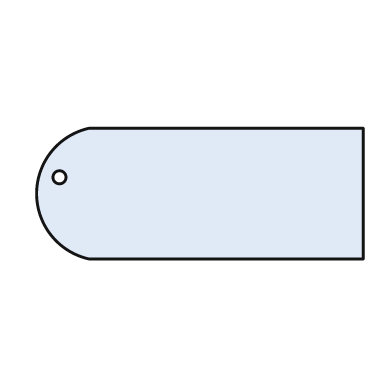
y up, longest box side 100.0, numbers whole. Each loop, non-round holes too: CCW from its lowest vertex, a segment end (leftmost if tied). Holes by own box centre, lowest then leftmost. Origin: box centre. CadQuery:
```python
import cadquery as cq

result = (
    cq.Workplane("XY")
    .moveTo(-34.0, -20.0)
    .lineTo(50.0, -20.0)
    .lineTo(50.0, 20.0)
    .lineTo(-34.0, 20.0)
    .threePointArc((-50.0, 0.0), (-34.0, -20.0))
    .close()
    .moveTo(-43.0, 5.0)
    .circle(2.0)
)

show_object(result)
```